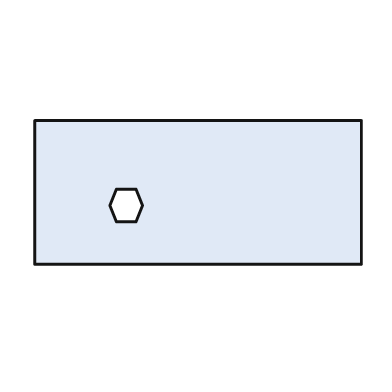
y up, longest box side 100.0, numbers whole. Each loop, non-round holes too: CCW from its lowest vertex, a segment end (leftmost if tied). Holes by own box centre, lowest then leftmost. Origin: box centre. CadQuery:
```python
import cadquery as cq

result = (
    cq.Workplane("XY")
    .moveTo(-50.0, -22.0)
    .lineTo(50.0, -22.0)
    .lineTo(50.0, 22.0)
    .lineTo(-50.0, 22.0)
    .close()
    .moveTo(-25.0, -9.0)
    .lineTo(-19.0, -9.0)
    .lineTo(-17.0, -4.0)
    .lineTo(-19.0, 1.0)
    .lineTo(-25.0, 1.0)
    .lineTo(-27.0, -4.0)
    .close()
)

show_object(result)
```